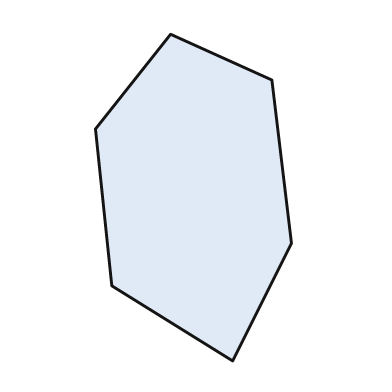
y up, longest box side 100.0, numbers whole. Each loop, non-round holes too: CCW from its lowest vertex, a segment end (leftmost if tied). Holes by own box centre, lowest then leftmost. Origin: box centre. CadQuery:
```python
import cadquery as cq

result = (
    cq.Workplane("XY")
    .moveTo(12.0, -50.0)
    .lineTo(30.0, -14.0)
    .lineTo(24.0, 36.0)
    .lineTo(-7.0, 50.0)
    .lineTo(-30.0, 21.0)
    .lineTo(-25.0, -27.0)
    .close()
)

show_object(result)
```